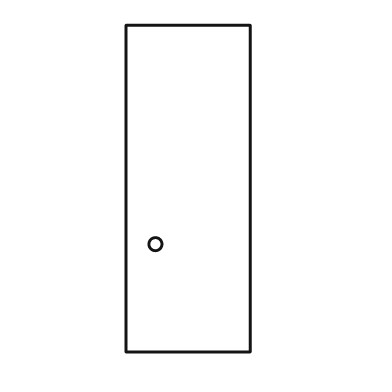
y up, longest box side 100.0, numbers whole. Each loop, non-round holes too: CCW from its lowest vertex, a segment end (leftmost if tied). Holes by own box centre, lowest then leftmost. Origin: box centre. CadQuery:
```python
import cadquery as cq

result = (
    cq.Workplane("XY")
    .moveTo(-19.0, -50.0)
    .lineTo(19.0, -50.0)
    .lineTo(19.0, 50.0)
    .lineTo(-19.0, 50.0)
    .close()
    .moveTo(-10.0, -17.0)
    .circle(2.0)
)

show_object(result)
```